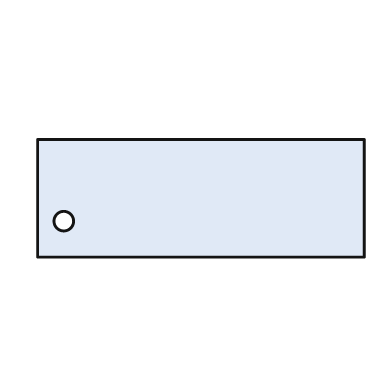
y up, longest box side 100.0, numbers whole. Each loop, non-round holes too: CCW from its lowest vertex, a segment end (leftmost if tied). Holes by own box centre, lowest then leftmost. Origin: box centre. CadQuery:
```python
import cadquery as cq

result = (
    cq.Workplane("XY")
    .moveTo(-50.0, -18.0)
    .lineTo(50.0, -18.0)
    .lineTo(50.0, 18.0)
    .lineTo(-50.0, 18.0)
    .close()
    .moveTo(-42.0, -7.0)
    .circle(3.0)
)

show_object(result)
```